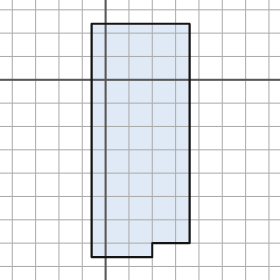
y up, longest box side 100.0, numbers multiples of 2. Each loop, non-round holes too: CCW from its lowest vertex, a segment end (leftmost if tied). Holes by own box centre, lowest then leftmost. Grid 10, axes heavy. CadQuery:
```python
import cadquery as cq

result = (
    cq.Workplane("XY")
    .moveTo(-6.0, -76.0)
    .lineTo(20.0, -76.0)
    .lineTo(20.0, -70.0)
    .lineTo(36.0, -70.0)
    .lineTo(36.0, 24.0)
    .lineTo(-6.0, 24.0)
    .close()
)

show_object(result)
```